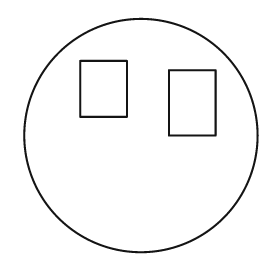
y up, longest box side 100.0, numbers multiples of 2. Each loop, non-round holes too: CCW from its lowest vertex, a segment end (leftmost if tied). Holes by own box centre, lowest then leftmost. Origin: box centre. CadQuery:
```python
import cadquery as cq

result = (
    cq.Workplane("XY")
    .moveTo(0.0, 0.0)
    .circle(50.0)
    .moveTo(12.0, 0.0)
    .lineTo(32.0, 0.0)
    .lineTo(32.0, 28.0)
    .lineTo(12.0, 28.0)
    .close()
    .moveTo(-26.0, 8.0)
    .lineTo(-6.0, 8.0)
    .lineTo(-6.0, 32.0)
    .lineTo(-26.0, 32.0)
    .close()
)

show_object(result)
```